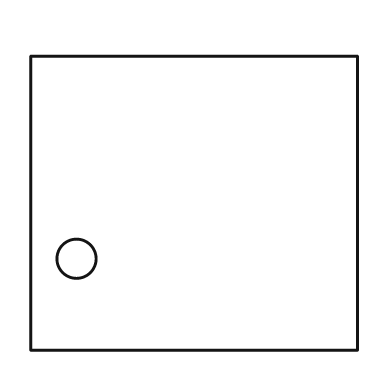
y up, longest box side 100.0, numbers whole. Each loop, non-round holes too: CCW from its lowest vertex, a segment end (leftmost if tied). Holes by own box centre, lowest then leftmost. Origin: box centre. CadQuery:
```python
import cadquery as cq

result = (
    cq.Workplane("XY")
    .moveTo(-50.0, -45.0)
    .lineTo(50.0, -45.0)
    .lineTo(50.0, 45.0)
    .lineTo(-50.0, 45.0)
    .close()
    .moveTo(-36.0, -17.0)
    .circle(6.0)
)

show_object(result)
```